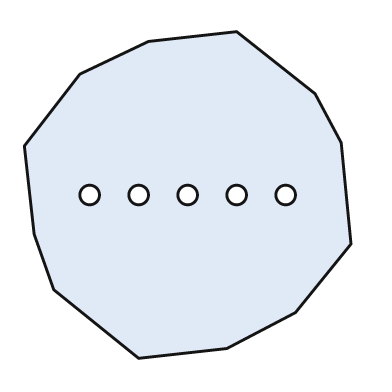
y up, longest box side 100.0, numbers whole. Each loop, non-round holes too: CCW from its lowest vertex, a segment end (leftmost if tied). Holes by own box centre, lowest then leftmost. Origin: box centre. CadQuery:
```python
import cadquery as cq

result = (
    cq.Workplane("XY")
    .moveTo(-15.0, -50.0)
    .lineTo(12.0, -47.0)
    .lineTo(33.0, -36.0)
    .lineTo(50.0, -15.0)
    .lineTo(47.0, 16.0)
    .lineTo(39.0, 31.0)
    .lineTo(15.0, 50.0)
    .lineTo(-12.0, 47.0)
    .lineTo(-33.0, 37.0)
    .lineTo(-50.0, 15.0)
    .lineTo(-47.0, -12.0)
    .lineTo(-41.0, -29.0)
    .close()
    .moveTo(-30.0, 0.0)
    .circle(3.0)
    .moveTo(-15.0, 0.0)
    .circle(3.0)
    .moveTo(0.0, 0.0)
    .circle(3.0)
    .moveTo(15.0, 0.0)
    .circle(3.0)
    .moveTo(30.0, 0.0)
    .circle(3.0)
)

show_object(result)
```